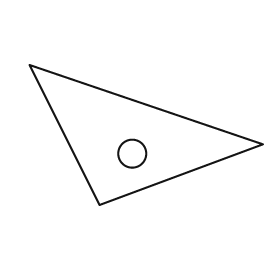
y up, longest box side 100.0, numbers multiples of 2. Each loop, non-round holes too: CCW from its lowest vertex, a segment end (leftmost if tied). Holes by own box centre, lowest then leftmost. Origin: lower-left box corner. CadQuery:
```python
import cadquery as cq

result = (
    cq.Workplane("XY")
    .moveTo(30.0, 0.0)
    .lineTo(100.0, 26.0)
    .lineTo(0.0, 60.0)
    .close()
    .moveTo(44.0, 22.0)
    .circle(6.0)
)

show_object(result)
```